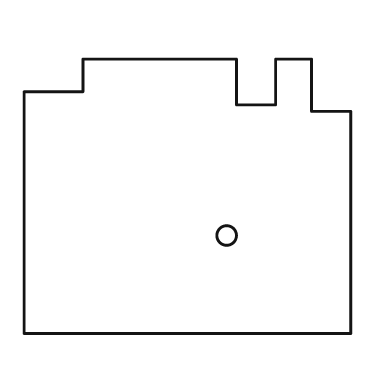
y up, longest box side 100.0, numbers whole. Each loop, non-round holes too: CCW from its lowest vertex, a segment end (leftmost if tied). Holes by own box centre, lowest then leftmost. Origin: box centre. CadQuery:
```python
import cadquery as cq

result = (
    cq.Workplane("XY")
    .moveTo(-50.0, -42.0)
    .lineTo(50.0, -42.0)
    .lineTo(50.0, 26.0)
    .lineTo(38.0, 26.0)
    .lineTo(38.0, 42.0)
    .lineTo(27.0, 42.0)
    .lineTo(27.0, 28.0)
    .lineTo(15.0, 28.0)
    .lineTo(15.0, 42.0)
    .lineTo(-32.0, 42.0)
    .lineTo(-32.0, 32.0)
    .lineTo(-50.0, 32.0)
    .close()
    .moveTo(12.0, -12.0)
    .circle(3.0)
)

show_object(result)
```